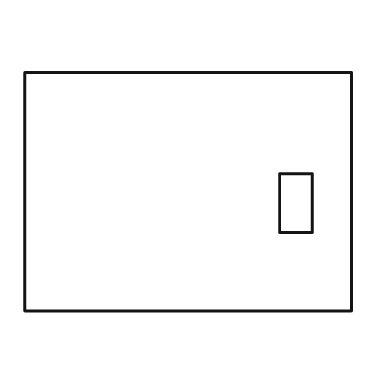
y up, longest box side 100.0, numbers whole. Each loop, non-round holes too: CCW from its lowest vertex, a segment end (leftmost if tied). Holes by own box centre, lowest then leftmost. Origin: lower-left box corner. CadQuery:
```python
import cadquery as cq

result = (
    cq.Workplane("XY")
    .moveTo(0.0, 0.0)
    .lineTo(100.0, 0.0)
    .lineTo(100.0, 73.0)
    .lineTo(0.0, 73.0)
    .close()
    .moveTo(78.0, 24.0)
    .lineTo(88.0, 24.0)
    .lineTo(88.0, 42.0)
    .lineTo(78.0, 42.0)
    .close()
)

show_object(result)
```